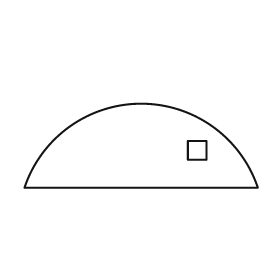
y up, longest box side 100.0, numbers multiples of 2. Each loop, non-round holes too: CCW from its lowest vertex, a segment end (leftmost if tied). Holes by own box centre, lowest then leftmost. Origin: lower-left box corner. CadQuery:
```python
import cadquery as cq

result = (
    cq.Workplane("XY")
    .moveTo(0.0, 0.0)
    .lineTo(100.0, 0.0)
    .threePointArc((50.0, 36.0), (0.0, 0.0))
    .close()
    .moveTo(70.0, 12.0)
    .lineTo(78.0, 12.0)
    .lineTo(78.0, 20.0)
    .lineTo(70.0, 20.0)
    .close()
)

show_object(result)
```